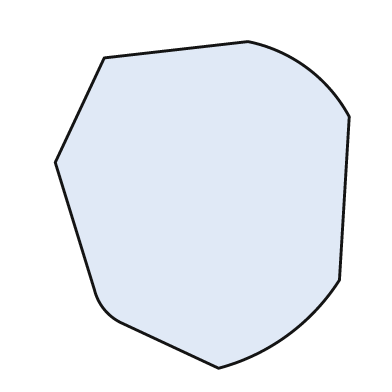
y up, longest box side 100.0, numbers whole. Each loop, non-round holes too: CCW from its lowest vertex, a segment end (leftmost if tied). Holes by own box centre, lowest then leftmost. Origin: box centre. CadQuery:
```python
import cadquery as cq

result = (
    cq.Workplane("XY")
    .moveTo(5.0, -50.0)
    .threePointArc((26.0, -40.0), (42.0, -23.0))
    .lineTo(45.0, 27.0)
    .threePointArc((32.0, 42.0), (14.0, 50.0))
    .lineTo(-30.0, 45.0)
    .lineTo(-45.0, 13.0)
    .lineTo(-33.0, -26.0)
    .threePointArc((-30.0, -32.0), (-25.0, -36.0))
    .close()
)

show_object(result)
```